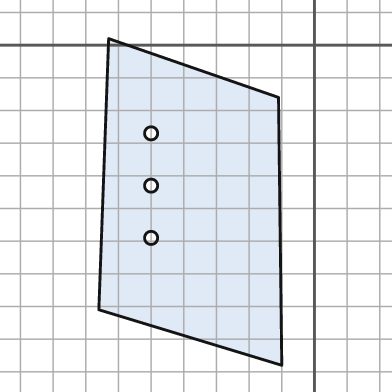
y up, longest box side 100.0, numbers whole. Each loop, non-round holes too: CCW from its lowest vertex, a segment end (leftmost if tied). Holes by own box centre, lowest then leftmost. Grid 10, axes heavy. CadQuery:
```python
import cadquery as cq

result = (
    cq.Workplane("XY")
    .moveTo(-10.0, -98.0)
    .lineTo(-11.0, -16.0)
    .lineTo(-63.0, 2.0)
    .lineTo(-66.0, -81.0)
    .close()
    .moveTo(-50.0, -59.0)
    .circle(2.0)
    .moveTo(-50.0, -43.0)
    .circle(2.0)
    .moveTo(-50.0, -27.0)
    .circle(2.0)
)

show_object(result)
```